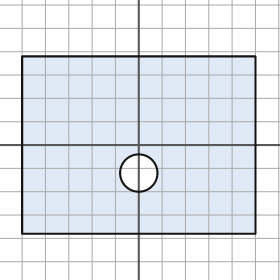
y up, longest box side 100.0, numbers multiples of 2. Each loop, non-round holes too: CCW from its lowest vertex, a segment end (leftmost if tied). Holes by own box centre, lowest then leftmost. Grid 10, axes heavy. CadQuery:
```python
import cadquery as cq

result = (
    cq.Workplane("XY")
    .moveTo(-50.0, -38.0)
    .lineTo(50.0, -38.0)
    .lineTo(50.0, 38.0)
    .lineTo(-50.0, 38.0)
    .close()
    .moveTo(0.0, -12.0)
    .circle(8.0)
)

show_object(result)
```